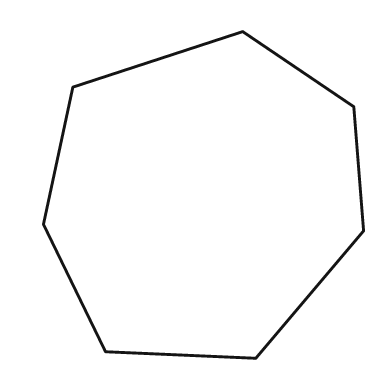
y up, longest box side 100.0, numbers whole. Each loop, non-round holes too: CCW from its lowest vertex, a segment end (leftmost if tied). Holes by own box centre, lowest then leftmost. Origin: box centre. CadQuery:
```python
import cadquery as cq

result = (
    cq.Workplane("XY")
    .moveTo(16.0, -50.0)
    .lineTo(49.0, -11.0)
    .lineTo(46.0, 27.0)
    .lineTo(12.0, 50.0)
    .lineTo(-40.0, 33.0)
    .lineTo(-49.0, -9.0)
    .lineTo(-30.0, -48.0)
    .close()
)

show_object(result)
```